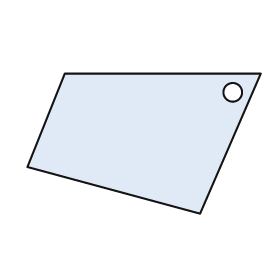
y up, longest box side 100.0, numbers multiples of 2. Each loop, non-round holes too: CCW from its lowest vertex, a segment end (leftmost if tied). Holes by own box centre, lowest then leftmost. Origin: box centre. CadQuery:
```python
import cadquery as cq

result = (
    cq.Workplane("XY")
    .moveTo(24.0, -30.0)
    .lineTo(50.0, 30.0)
    .lineTo(-34.0, 30.0)
    .lineTo(-50.0, -10.0)
    .close()
    .moveTo(38.0, 22.0)
    .circle(4.0)
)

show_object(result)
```